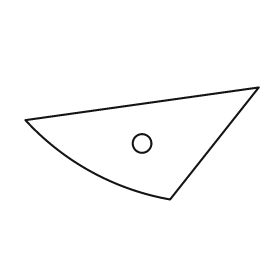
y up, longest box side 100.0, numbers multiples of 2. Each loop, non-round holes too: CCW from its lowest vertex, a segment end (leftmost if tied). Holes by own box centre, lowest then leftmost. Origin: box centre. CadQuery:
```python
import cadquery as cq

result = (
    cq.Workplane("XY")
    .moveTo(12.0, -24.0)
    .lineTo(50.0, 24.0)
    .lineTo(-50.0, 10.0)
    .threePointArc((-22.0, -12.0), (12.0, -24.0))
    .close()
    .moveTo(0.0, 0.0)
    .circle(4.0)
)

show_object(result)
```